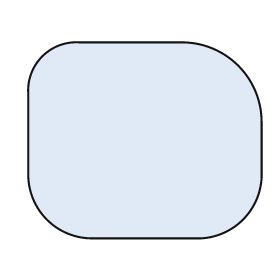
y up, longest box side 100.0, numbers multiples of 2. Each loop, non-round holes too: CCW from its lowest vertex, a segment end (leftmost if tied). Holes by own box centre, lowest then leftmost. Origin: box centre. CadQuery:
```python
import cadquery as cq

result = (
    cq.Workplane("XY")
    .moveTo(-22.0, -42.0)
    .lineTo(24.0, -42.0)
    .threePointArc((42.0, -34.0), (50.0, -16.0))
    .lineTo(50.0, 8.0)
    .threePointArc((40.0, 32.0), (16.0, 42.0))
    .lineTo(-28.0, 42.0)
    .threePointArc((-44.0, 36.0), (-50.0, 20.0))
    .lineTo(-50.0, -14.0)
    .threePointArc((-42.0, -34.0), (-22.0, -42.0))
    .close()
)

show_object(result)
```